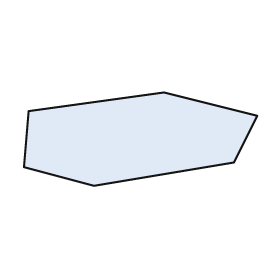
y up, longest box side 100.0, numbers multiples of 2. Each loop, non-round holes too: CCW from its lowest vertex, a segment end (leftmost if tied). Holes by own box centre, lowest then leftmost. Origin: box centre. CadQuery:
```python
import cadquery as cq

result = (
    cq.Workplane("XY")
    .moveTo(-20.0, -20.0)
    .lineTo(40.0, -10.0)
    .lineTo(50.0, 10.0)
    .lineTo(10.0, 20.0)
    .lineTo(-48.0, 12.0)
    .lineTo(-50.0, -12.0)
    .close()
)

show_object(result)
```